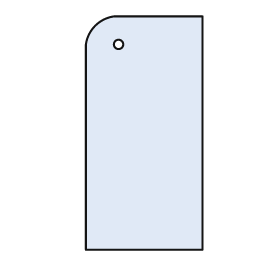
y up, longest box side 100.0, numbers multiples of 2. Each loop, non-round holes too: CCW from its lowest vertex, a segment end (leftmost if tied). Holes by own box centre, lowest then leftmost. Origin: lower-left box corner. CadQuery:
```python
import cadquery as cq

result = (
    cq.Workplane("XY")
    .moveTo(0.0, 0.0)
    .lineTo(50.0, 0.0)
    .lineTo(50.0, 100.0)
    .lineTo(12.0, 100.0)
    .threePointArc((4.0, 96.0), (0.0, 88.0))
    .close()
    .moveTo(14.0, 88.0)
    .circle(2.0)
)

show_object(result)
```